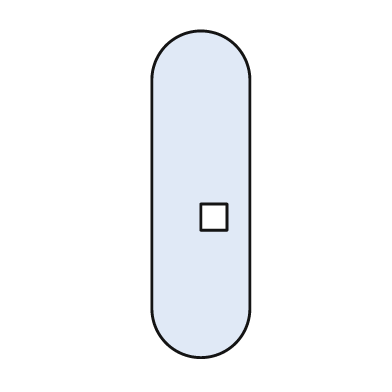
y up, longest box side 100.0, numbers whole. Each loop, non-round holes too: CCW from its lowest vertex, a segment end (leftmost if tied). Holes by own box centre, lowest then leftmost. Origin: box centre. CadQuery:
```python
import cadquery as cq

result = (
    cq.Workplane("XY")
    .moveTo(-15.0, -35.0)
    .threePointArc((0.0, -50.0), (15.0, -35.0))
    .lineTo(15.0, 35.0)
    .threePointArc((0.0, 50.0), (-15.0, 35.0))
    .close()
    .moveTo(0.0, -11.0)
    .lineTo(8.0, -11.0)
    .lineTo(8.0, -3.0)
    .lineTo(0.0, -3.0)
    .close()
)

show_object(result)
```